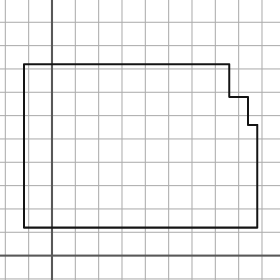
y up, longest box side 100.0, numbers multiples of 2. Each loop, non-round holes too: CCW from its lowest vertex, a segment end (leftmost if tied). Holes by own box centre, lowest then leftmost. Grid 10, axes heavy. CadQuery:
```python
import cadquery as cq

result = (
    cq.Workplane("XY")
    .moveTo(-12.0, 12.0)
    .lineTo(88.0, 12.0)
    .lineTo(88.0, 56.0)
    .lineTo(84.0, 56.0)
    .lineTo(84.0, 68.0)
    .lineTo(76.0, 68.0)
    .lineTo(76.0, 82.0)
    .lineTo(-12.0, 82.0)
    .close()
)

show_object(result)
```